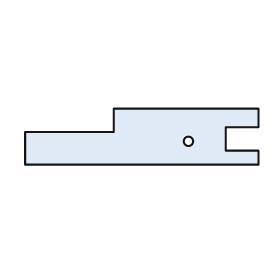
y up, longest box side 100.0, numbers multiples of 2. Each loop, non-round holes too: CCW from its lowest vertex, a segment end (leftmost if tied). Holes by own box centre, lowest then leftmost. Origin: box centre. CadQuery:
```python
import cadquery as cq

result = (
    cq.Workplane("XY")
    .moveTo(-50.0, -12.0)
    .lineTo(50.0, -12.0)
    .lineTo(50.0, -6.0)
    .lineTo(36.0, -6.0)
    .lineTo(36.0, 4.0)
    .lineTo(50.0, 4.0)
    .lineTo(50.0, 12.0)
    .lineTo(-12.0, 12.0)
    .lineTo(-12.0, 2.0)
    .lineTo(-50.0, 2.0)
    .close()
    .moveTo(20.0, -2.0)
    .circle(2.0)
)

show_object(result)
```